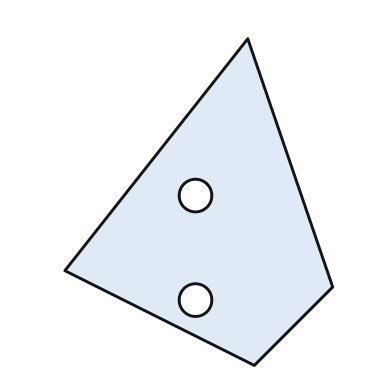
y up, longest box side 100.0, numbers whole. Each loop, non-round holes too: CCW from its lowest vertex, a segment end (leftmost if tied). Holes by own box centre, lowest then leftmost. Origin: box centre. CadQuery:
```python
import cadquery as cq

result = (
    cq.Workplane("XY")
    .moveTo(17.0, -50.0)
    .lineTo(41.0, -26.0)
    .lineTo(15.0, 50.0)
    .lineTo(-41.0, -21.0)
    .close()
    .moveTo(-1.0, -30.0)
    .circle(5.0)
    .moveTo(-1.0, 2.0)
    .circle(5.0)
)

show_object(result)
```